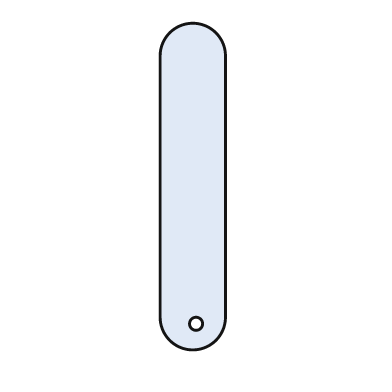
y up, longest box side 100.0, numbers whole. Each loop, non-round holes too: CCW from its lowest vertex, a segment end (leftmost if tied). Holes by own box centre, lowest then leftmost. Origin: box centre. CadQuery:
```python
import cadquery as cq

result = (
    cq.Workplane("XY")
    .moveTo(-10.0, -40.0)
    .threePointArc((0.0, -50.0), (10.0, -40.0))
    .lineTo(10.0, 40.0)
    .threePointArc((0.0, 50.0), (-10.0, 40.0))
    .close()
    .moveTo(1.0, -42.0)
    .circle(2.0)
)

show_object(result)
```